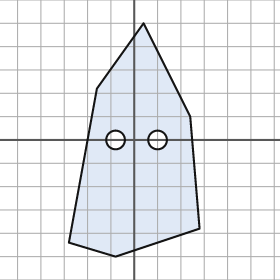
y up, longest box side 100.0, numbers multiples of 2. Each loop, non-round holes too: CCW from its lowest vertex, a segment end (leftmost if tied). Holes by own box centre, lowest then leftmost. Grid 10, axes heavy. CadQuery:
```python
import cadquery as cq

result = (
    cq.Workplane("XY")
    .moveTo(-8.0, -50.0)
    .lineTo(28.0, -38.0)
    .lineTo(24.0, 10.0)
    .lineTo(4.0, 50.0)
    .lineTo(-16.0, 22.0)
    .lineTo(-28.0, -44.0)
    .close()
    .moveTo(-8.0, 0.0)
    .circle(4.0)
    .moveTo(10.0, 0.0)
    .circle(4.0)
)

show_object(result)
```